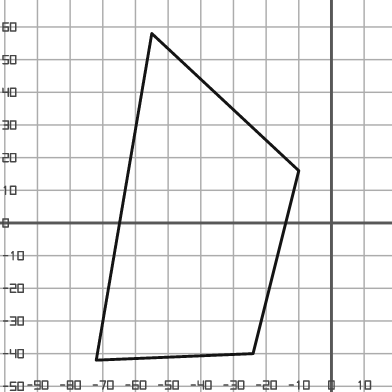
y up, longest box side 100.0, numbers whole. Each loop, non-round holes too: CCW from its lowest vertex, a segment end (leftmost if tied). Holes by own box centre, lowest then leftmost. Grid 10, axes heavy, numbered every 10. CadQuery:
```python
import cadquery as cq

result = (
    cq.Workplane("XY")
    .moveTo(-72.0, -42.0)
    .lineTo(-24.0, -40.0)
    .lineTo(-10.0, 16.0)
    .lineTo(-55.0, 58.0)
    .close()
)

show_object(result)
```